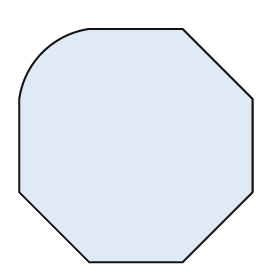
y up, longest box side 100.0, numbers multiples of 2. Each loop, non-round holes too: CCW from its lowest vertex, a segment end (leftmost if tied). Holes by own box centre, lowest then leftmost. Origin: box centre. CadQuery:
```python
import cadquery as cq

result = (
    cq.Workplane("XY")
    .moveTo(-20.0, -50.0)
    .lineTo(20.0, -50.0)
    .lineTo(50.0, -20.0)
    .lineTo(50.0, 20.0)
    .lineTo(20.0, 50.0)
    .lineTo(-20.0, 50.0)
    .threePointArc((-40.0, 40.0), (-50.0, 20.0))
    .lineTo(-50.0, -20.0)
    .close()
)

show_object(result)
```